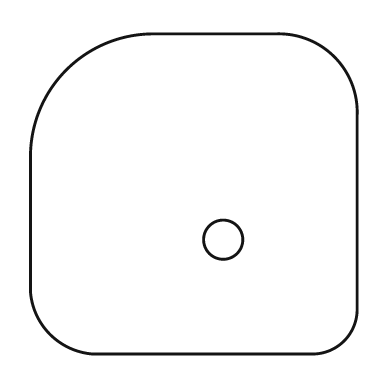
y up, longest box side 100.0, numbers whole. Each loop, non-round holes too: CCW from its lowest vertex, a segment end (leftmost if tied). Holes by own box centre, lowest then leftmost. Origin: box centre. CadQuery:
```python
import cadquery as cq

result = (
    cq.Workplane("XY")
    .moveTo(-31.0, -49.0)
    .lineTo(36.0, -49.0)
    .threePointArc((46.0, -45.0), (50.0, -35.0))
    .lineTo(50.0, 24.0)
    .threePointArc((43.0, 42.0), (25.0, 49.0))
    .lineTo(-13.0, 49.0)
    .threePointArc((-39.0, 38.0), (-50.0, 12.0))
    .lineTo(-50.0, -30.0)
    .threePointArc((-44.0, -43.0), (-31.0, -49.0))
    .close()
    .moveTo(9.0, -14.0)
    .circle(6.0)
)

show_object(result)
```